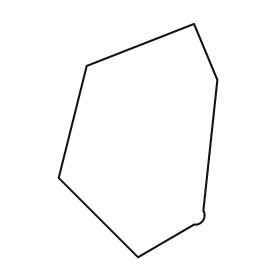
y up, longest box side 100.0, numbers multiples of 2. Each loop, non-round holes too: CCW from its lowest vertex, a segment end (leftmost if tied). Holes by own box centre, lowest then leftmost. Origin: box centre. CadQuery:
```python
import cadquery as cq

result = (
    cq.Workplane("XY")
    .moveTo(0.0, -50.0)
    .lineTo(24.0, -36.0)
    .threePointArc((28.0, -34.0), (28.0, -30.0))
    .lineTo(34.0, 26.0)
    .lineTo(24.0, 50.0)
    .lineTo(-22.0, 32.0)
    .lineTo(-34.0, -16.0)
    .close()
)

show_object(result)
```